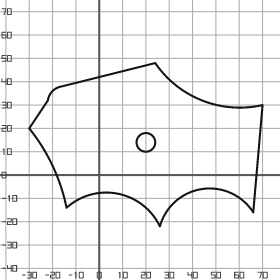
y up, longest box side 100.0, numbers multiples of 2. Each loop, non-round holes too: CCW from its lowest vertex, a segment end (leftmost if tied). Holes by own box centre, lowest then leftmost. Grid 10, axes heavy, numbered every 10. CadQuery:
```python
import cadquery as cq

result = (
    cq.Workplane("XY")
    .moveTo(26.0, -22.0)
    .threePointArc((44.0, -6.0), (66.0, -16.0))
    .lineTo(70.0, 30.0)
    .threePointArc((44.0, 32.0), (24.0, 48.0))
    .lineTo(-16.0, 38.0)
    .threePointArc((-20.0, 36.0), (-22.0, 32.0))
    .lineTo(-30.0, 20.0)
    .threePointArc((-20.0, 4.0), (-14.0, -14.0))
    .threePointArc((8.0, -8.0), (26.0, -22.0))
    .close()
    .moveTo(20.0, 14.0)
    .circle(4.0)
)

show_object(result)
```